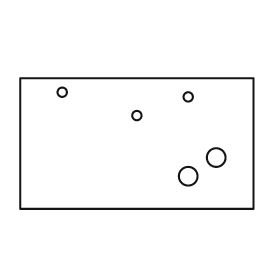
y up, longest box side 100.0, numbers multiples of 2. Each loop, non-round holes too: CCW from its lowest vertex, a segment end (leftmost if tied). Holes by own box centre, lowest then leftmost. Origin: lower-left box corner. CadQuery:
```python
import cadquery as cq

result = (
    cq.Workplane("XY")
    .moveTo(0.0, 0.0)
    .lineTo(100.0, 0.0)
    .lineTo(100.0, 56.0)
    .lineTo(0.0, 56.0)
    .close()
    .moveTo(72.0, 14.0)
    .circle(4.0)
    .moveTo(84.0, 22.0)
    .circle(4.0)
    .moveTo(50.0, 40.0)
    .circle(2.0)
    .moveTo(72.0, 48.0)
    .circle(2.0)
    .moveTo(18.0, 50.0)
    .circle(2.0)
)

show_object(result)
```